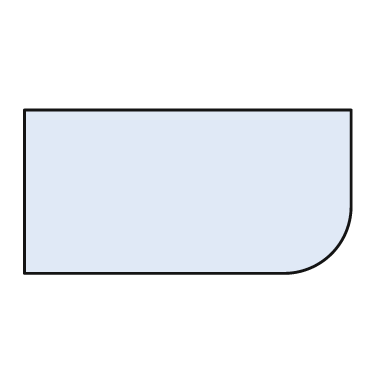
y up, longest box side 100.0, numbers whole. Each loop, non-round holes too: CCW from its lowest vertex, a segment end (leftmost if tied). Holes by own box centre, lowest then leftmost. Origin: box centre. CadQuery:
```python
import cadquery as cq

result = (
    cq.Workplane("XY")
    .moveTo(-50.0, -25.0)
    .lineTo(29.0, -25.0)
    .threePointArc((44.0, -19.0), (50.0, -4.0))
    .lineTo(50.0, 25.0)
    .lineTo(-50.0, 25.0)
    .close()
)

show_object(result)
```